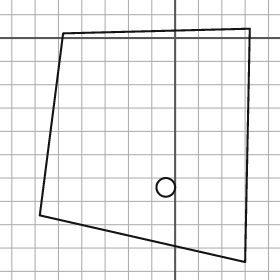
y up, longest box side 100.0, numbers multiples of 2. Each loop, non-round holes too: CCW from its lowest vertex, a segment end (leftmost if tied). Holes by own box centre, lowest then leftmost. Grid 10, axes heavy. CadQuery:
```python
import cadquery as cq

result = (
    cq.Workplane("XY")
    .moveTo(30.0, -96.0)
    .lineTo(32.0, 4.0)
    .lineTo(-48.0, 2.0)
    .lineTo(-58.0, -76.0)
    .close()
    .moveTo(-4.0, -64.0)
    .circle(4.0)
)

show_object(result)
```